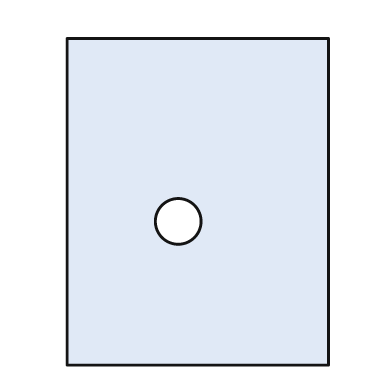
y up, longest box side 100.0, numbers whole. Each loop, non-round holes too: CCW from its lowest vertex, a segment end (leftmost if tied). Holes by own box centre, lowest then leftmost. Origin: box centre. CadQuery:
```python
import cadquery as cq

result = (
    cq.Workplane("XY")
    .moveTo(-40.0, -50.0)
    .lineTo(40.0, -50.0)
    .lineTo(40.0, 50.0)
    .lineTo(-40.0, 50.0)
    .close()
    .moveTo(-6.0, -6.0)
    .circle(7.0)
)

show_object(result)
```